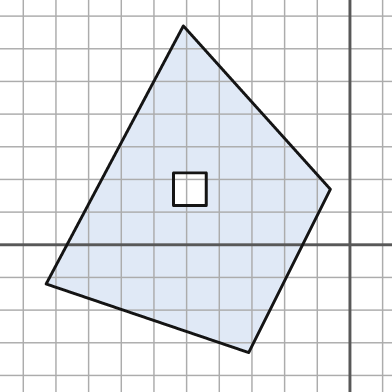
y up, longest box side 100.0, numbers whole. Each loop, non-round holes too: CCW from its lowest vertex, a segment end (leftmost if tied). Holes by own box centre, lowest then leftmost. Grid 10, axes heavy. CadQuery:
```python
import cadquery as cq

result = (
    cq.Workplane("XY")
    .moveTo(-31.0, -33.0)
    .lineTo(-6.0, 17.0)
    .lineTo(-51.0, 67.0)
    .lineTo(-93.0, -12.0)
    .close()
    .moveTo(-54.0, 12.0)
    .lineTo(-44.0, 12.0)
    .lineTo(-44.0, 22.0)
    .lineTo(-54.0, 22.0)
    .close()
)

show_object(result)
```